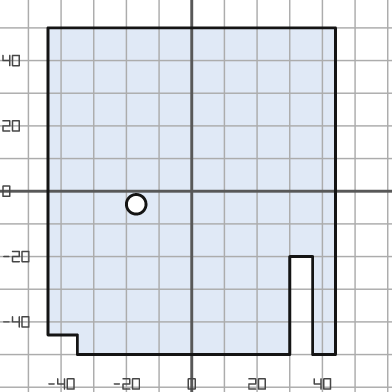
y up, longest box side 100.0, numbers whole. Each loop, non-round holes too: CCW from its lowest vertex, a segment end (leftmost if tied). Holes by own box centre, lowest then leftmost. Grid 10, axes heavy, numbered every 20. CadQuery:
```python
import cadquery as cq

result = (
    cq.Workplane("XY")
    .moveTo(-35.0, -50.0)
    .lineTo(30.0, -50.0)
    .lineTo(30.0, -20.0)
    .lineTo(37.0, -20.0)
    .lineTo(37.0, -50.0)
    .lineTo(44.0, -50.0)
    .lineTo(44.0, 50.0)
    .lineTo(-44.0, 50.0)
    .lineTo(-44.0, -44.0)
    .lineTo(-35.0, -44.0)
    .close()
    .moveTo(-17.0, -4.0)
    .circle(3.0)
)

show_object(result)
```